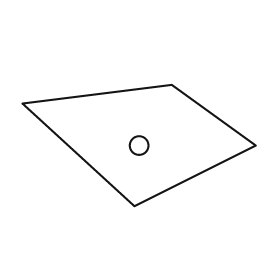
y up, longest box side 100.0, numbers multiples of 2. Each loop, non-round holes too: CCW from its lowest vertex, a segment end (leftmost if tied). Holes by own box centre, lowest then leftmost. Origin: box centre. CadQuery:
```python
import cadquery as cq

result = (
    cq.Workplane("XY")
    .moveTo(-2.0, -26.0)
    .lineTo(50.0, 0.0)
    .lineTo(14.0, 26.0)
    .lineTo(-50.0, 18.0)
    .close()
    .moveTo(0.0, 0.0)
    .circle(4.0)
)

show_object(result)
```